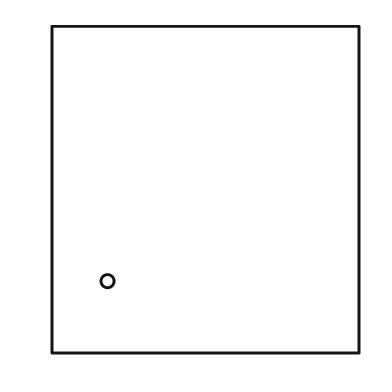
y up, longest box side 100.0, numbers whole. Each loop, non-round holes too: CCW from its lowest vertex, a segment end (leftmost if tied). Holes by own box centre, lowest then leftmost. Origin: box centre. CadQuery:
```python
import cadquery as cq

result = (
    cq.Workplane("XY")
    .moveTo(-47.0, -50.0)
    .lineTo(47.0, -50.0)
    .lineTo(47.0, 50.0)
    .lineTo(-47.0, 50.0)
    .close()
    .moveTo(-30.0, -28.0)
    .circle(2.0)
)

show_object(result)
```